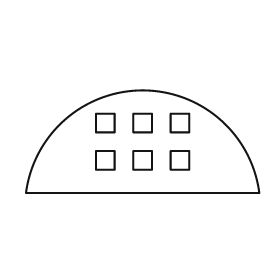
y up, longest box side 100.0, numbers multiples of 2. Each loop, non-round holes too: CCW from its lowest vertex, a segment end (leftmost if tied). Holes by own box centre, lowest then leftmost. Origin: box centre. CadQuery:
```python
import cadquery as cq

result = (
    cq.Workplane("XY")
    .moveTo(-50.0, -22.0)
    .lineTo(50.0, -22.0)
    .threePointArc((0.0, 22.0), (-50.0, -22.0))
    .close()
    .moveTo(-20.0, -12.0)
    .lineTo(-12.0, -12.0)
    .lineTo(-12.0, -4.0)
    .lineTo(-20.0, -4.0)
    .close()
    .moveTo(-4.0, -12.0)
    .lineTo(4.0, -12.0)
    .lineTo(4.0, -4.0)
    .lineTo(-4.0, -4.0)
    .close()
    .moveTo(12.0, -12.0)
    .lineTo(20.0, -12.0)
    .lineTo(20.0, -4.0)
    .lineTo(12.0, -4.0)
    .close()
    .moveTo(-20.0, 4.0)
    .lineTo(-12.0, 4.0)
    .lineTo(-12.0, 12.0)
    .lineTo(-20.0, 12.0)
    .close()
    .moveTo(-4.0, 4.0)
    .lineTo(4.0, 4.0)
    .lineTo(4.0, 12.0)
    .lineTo(-4.0, 12.0)
    .close()
    .moveTo(12.0, 4.0)
    .lineTo(20.0, 4.0)
    .lineTo(20.0, 12.0)
    .lineTo(12.0, 12.0)
    .close()
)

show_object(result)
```